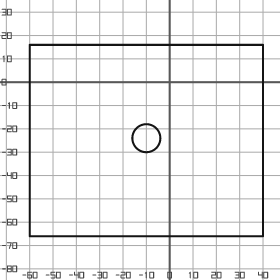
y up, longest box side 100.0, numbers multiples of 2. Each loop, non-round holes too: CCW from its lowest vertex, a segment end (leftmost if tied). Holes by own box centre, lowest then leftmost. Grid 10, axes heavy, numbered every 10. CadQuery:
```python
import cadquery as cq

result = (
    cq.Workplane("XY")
    .moveTo(-60.0, -66.0)
    .lineTo(40.0, -66.0)
    .lineTo(40.0, 16.0)
    .lineTo(-60.0, 16.0)
    .close()
    .moveTo(-10.0, -24.0)
    .circle(6.0)
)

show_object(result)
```